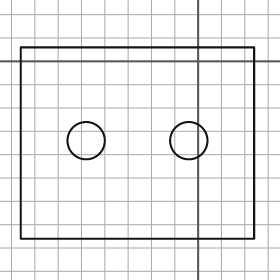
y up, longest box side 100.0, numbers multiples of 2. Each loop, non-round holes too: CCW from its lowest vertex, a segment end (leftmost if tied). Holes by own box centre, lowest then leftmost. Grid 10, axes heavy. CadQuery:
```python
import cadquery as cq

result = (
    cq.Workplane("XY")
    .moveTo(-76.0, -76.0)
    .lineTo(24.0, -76.0)
    .lineTo(24.0, 6.0)
    .lineTo(-76.0, 6.0)
    .close()
    .moveTo(-48.0, -34.0)
    .circle(8.0)
    .moveTo(-4.0, -34.0)
    .circle(8.0)
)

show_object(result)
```